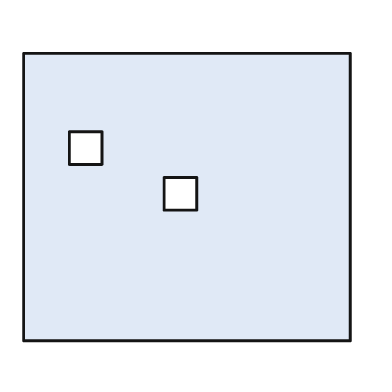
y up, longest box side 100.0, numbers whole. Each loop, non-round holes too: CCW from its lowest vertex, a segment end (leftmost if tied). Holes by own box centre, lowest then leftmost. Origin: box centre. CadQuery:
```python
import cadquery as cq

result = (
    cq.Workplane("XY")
    .moveTo(-50.0, -44.0)
    .lineTo(50.0, -44.0)
    .lineTo(50.0, 44.0)
    .lineTo(-50.0, 44.0)
    .close()
    .moveTo(-7.0, -4.0)
    .lineTo(3.0, -4.0)
    .lineTo(3.0, 6.0)
    .lineTo(-7.0, 6.0)
    .close()
    .moveTo(-36.0, 10.0)
    .lineTo(-26.0, 10.0)
    .lineTo(-26.0, 20.0)
    .lineTo(-36.0, 20.0)
    .close()
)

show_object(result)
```